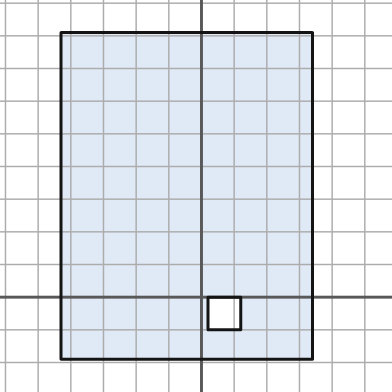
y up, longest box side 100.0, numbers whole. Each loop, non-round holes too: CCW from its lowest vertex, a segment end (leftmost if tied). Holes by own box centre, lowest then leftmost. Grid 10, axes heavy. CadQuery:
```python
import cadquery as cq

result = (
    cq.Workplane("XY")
    .moveTo(-43.0, -19.0)
    .lineTo(34.0, -19.0)
    .lineTo(34.0, 81.0)
    .lineTo(-43.0, 81.0)
    .close()
    .moveTo(2.0, -10.0)
    .lineTo(12.0, -10.0)
    .lineTo(12.0, 0.0)
    .lineTo(2.0, 0.0)
    .close()
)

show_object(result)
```